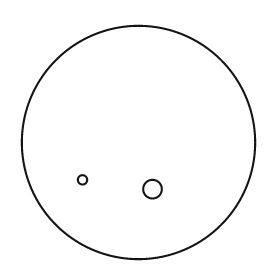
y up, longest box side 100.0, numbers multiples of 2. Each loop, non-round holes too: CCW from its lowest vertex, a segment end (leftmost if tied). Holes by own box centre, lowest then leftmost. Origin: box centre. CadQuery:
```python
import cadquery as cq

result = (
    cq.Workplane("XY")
    .moveTo(0.0, 0.0)
    .circle(50.0)
    .moveTo(6.0, -20.0)
    .circle(4.0)
    .moveTo(-24.0, -16.0)
    .circle(2.0)
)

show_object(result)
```